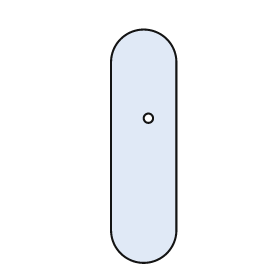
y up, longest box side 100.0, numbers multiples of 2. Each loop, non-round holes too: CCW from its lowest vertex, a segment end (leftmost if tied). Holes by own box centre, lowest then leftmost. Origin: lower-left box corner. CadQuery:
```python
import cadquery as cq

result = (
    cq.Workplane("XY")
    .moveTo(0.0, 14.0)
    .threePointArc((14.0, 0.0), (28.0, 14.0))
    .lineTo(28.0, 86.0)
    .threePointArc((14.0, 100.0), (0.0, 86.0))
    .close()
    .moveTo(16.0, 62.0)
    .circle(2.0)
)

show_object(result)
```